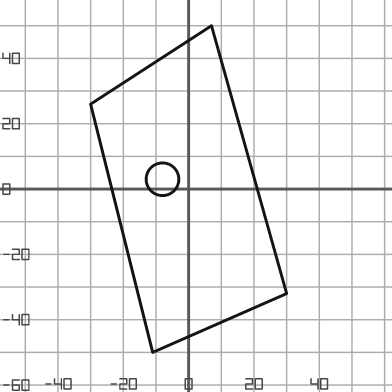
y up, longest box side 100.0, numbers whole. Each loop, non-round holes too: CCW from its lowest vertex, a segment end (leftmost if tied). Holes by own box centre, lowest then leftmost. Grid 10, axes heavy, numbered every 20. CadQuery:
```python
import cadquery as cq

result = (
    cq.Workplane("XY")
    .moveTo(-11.0, -50.0)
    .lineTo(30.0, -32.0)
    .lineTo(7.0, 50.0)
    .lineTo(-30.0, 26.0)
    .close()
    .moveTo(-8.0, 3.0)
    .circle(5.0)
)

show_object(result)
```